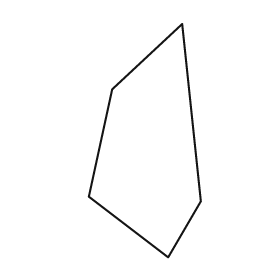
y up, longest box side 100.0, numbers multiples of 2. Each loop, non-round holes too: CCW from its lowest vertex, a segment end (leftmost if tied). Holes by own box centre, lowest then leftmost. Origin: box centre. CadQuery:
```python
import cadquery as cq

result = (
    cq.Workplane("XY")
    .moveTo(10.0, -50.0)
    .lineTo(24.0, -26.0)
    .lineTo(16.0, 50.0)
    .lineTo(-14.0, 22.0)
    .lineTo(-24.0, -24.0)
    .close()
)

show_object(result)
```